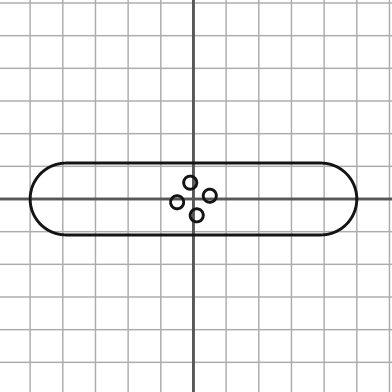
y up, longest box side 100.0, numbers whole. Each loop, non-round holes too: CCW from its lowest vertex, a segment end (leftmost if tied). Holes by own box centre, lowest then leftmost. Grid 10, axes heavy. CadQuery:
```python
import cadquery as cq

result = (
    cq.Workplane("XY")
    .moveTo(-39.0, -11.0)
    .lineTo(39.0, -11.0)
    .threePointArc((50.0, 0.0), (39.0, 11.0))
    .lineTo(-39.0, 11.0)
    .threePointArc((-50.0, 0.0), (-39.0, -11.0))
    .close()
    .moveTo(1.0, -5.0)
    .circle(2.0)
    .moveTo(-5.0, -1.0)
    .circle(2.0)
    .moveTo(5.0, 1.0)
    .circle(2.0)
    .moveTo(-1.0, 5.0)
    .circle(2.0)
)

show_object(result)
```